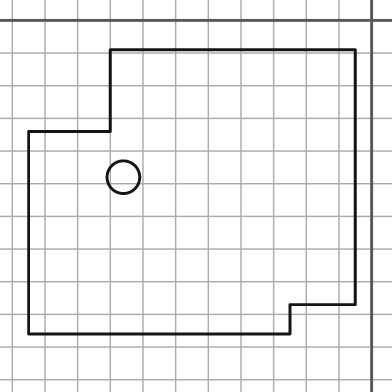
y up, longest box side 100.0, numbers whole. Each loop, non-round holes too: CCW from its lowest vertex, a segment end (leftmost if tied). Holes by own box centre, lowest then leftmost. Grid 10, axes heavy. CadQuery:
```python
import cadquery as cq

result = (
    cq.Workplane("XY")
    .moveTo(-105.0, -96.0)
    .lineTo(-25.0, -96.0)
    .lineTo(-25.0, -87.0)
    .lineTo(-5.0, -87.0)
    .lineTo(-5.0, -9.0)
    .lineTo(-80.0, -9.0)
    .lineTo(-80.0, -34.0)
    .lineTo(-105.0, -34.0)
    .close()
    .moveTo(-76.0, -48.0)
    .circle(5.0)
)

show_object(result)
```